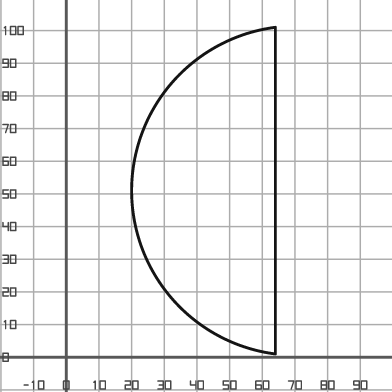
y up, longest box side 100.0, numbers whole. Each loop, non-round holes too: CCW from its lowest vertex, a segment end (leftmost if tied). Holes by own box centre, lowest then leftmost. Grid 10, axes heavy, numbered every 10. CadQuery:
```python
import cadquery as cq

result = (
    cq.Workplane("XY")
    .moveTo(64.0, 1.0)
    .lineTo(64.0, 101.0)
    .threePointArc((20.0, 51.0), (64.0, 1.0))
    .close()
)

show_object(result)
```